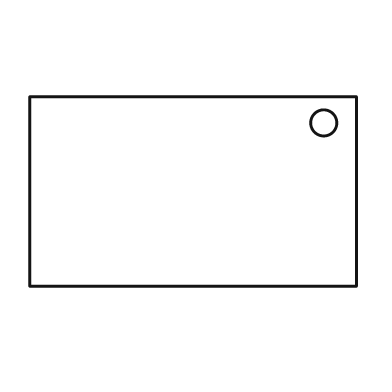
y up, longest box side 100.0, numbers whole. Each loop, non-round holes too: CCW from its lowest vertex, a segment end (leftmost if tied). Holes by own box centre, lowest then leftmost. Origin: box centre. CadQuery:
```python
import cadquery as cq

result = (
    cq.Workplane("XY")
    .moveTo(-50.0, -29.0)
    .lineTo(50.0, -29.0)
    .lineTo(50.0, 29.0)
    .lineTo(-50.0, 29.0)
    .close()
    .moveTo(40.0, 21.0)
    .circle(4.0)
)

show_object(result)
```